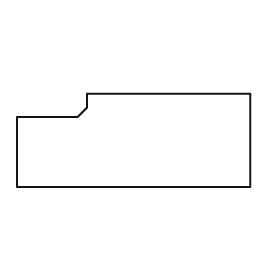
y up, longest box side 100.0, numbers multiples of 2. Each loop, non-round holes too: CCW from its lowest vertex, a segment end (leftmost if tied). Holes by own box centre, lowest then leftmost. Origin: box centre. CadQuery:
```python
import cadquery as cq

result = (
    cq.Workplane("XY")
    .moveTo(-50.0, -20.0)
    .lineTo(50.0, -20.0)
    .lineTo(50.0, 20.0)
    .lineTo(-20.0, 20.0)
    .lineTo(-20.0, 14.0)
    .lineTo(-24.0, 10.0)
    .lineTo(-50.0, 10.0)
    .close()
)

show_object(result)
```